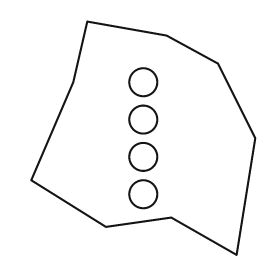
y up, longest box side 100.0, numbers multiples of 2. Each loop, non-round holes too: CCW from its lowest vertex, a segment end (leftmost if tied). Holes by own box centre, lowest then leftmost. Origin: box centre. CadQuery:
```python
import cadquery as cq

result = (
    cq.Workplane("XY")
    .moveTo(40.0, -50.0)
    .lineTo(48.0, 0.0)
    .lineTo(32.0, 32.0)
    .lineTo(10.0, 44.0)
    .lineTo(-24.0, 50.0)
    .lineTo(-30.0, 24.0)
    .lineTo(-48.0, -18.0)
    .lineTo(-16.0, -38.0)
    .lineTo(12.0, -34.0)
    .close()
    .moveTo(0.0, -24.0)
    .circle(6.0)
    .moveTo(0.0, -8.0)
    .circle(6.0)
    .moveTo(0.0, 8.0)
    .circle(6.0)
    .moveTo(0.0, 24.0)
    .circle(6.0)
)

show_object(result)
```